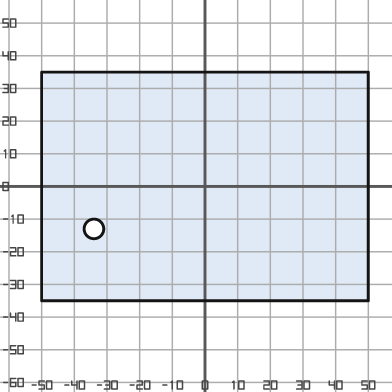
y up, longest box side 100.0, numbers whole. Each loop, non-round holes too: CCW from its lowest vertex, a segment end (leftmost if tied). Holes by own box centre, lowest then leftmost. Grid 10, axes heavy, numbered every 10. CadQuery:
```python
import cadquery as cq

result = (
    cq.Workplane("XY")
    .moveTo(-50.0, -35.0)
    .lineTo(50.0, -35.0)
    .lineTo(50.0, 35.0)
    .lineTo(-50.0, 35.0)
    .close()
    .moveTo(-34.0, -13.0)
    .circle(3.0)
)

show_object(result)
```